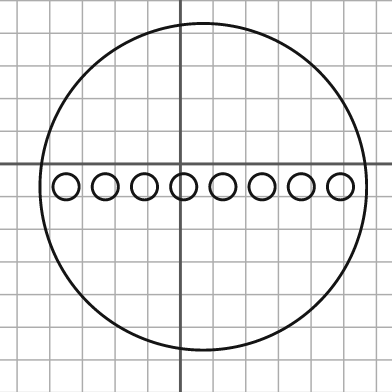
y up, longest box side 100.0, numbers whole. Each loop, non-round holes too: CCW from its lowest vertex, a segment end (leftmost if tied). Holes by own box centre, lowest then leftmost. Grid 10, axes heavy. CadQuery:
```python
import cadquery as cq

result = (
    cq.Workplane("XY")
    .moveTo(7.0, -7.0)
    .circle(50.0)
    .moveTo(-35.0, -7.0)
    .circle(4.0)
    .moveTo(-23.0, -7.0)
    .circle(4.0)
    .moveTo(-11.0, -7.0)
    .circle(4.0)
    .moveTo(1.0, -7.0)
    .circle(4.0)
    .moveTo(13.0, -7.0)
    .circle(4.0)
    .moveTo(25.0, -7.0)
    .circle(4.0)
    .moveTo(37.0, -7.0)
    .circle(4.0)
    .moveTo(49.0, -7.0)
    .circle(4.0)
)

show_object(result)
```